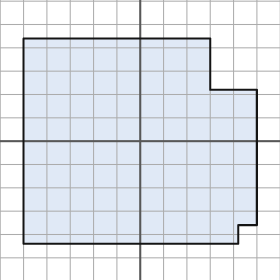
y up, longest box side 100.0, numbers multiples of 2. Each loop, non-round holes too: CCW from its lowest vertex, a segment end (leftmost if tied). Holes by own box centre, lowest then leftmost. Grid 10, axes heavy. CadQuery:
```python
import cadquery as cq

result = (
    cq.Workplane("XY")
    .moveTo(-50.0, -44.0)
    .lineTo(42.0, -44.0)
    .lineTo(42.0, -36.0)
    .lineTo(50.0, -36.0)
    .lineTo(50.0, 22.0)
    .lineTo(30.0, 22.0)
    .lineTo(30.0, 44.0)
    .lineTo(-50.0, 44.0)
    .close()
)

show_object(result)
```